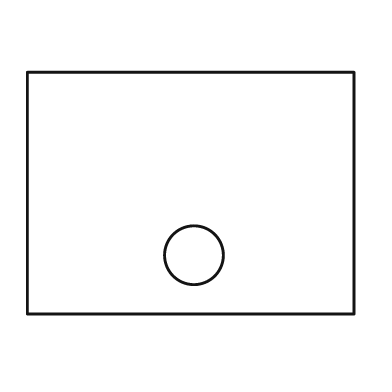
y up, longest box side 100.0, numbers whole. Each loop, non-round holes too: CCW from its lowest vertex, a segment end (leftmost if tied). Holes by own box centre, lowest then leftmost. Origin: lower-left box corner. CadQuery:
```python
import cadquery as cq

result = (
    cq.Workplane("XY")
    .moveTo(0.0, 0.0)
    .lineTo(100.0, 0.0)
    .lineTo(100.0, 74.0)
    .lineTo(0.0, 74.0)
    .close()
    .moveTo(51.0, 18.0)
    .circle(9.0)
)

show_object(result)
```